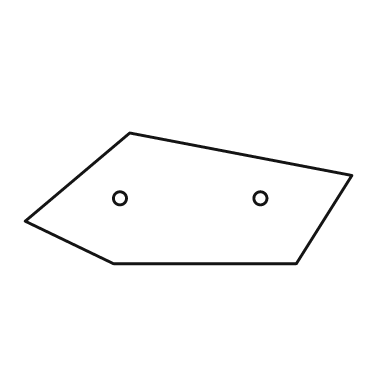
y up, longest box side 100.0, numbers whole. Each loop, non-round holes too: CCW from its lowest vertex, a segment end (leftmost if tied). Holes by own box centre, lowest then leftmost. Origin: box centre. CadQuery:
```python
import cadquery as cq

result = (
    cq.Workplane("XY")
    .moveTo(-23.0, -20.0)
    .lineTo(33.0, -20.0)
    .lineTo(50.0, 7.0)
    .lineTo(-18.0, 20.0)
    .lineTo(-50.0, -7.0)
    .close()
    .moveTo(-21.0, 0.0)
    .circle(2.0)
    .moveTo(22.0, 0.0)
    .circle(2.0)
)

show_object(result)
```